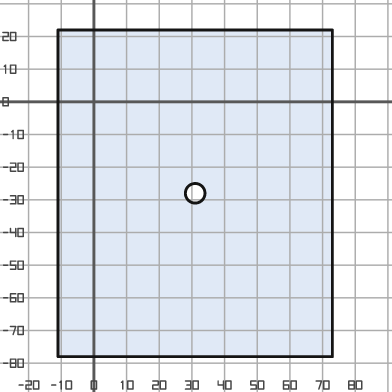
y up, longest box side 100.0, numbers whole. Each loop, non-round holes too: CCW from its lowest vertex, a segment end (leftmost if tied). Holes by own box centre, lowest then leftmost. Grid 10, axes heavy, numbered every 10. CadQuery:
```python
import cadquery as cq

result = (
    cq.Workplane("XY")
    .moveTo(-11.0, -78.0)
    .lineTo(73.0, -78.0)
    .lineTo(73.0, 22.0)
    .lineTo(-11.0, 22.0)
    .close()
    .moveTo(31.0, -28.0)
    .circle(3.0)
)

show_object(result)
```